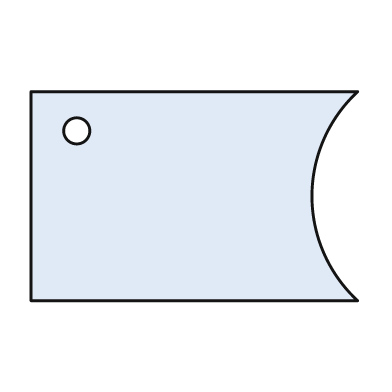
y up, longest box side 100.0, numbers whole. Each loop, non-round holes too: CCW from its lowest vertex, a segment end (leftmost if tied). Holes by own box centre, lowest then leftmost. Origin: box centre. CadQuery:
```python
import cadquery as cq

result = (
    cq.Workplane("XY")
    .moveTo(-50.0, -32.0)
    .lineTo(50.0, -32.0)
    .threePointArc((36.0, 0.0), (50.0, 32.0))
    .lineTo(-50.0, 32.0)
    .close()
    .moveTo(-36.0, 20.0)
    .circle(4.0)
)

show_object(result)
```